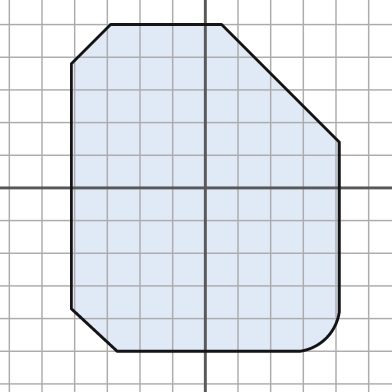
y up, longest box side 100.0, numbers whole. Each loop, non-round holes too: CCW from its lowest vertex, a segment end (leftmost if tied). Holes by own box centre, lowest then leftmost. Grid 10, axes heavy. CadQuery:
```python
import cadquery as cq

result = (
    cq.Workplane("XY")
    .moveTo(-27.0, -50.0)
    .lineTo(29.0, -50.0)
    .threePointArc((37.0, -46.0), (41.0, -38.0))
    .lineTo(41.0, 14.0)
    .lineTo(5.0, 50.0)
    .lineTo(-29.0, 50.0)
    .lineTo(-41.0, 38.0)
    .lineTo(-41.0, -37.0)
    .close()
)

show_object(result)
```